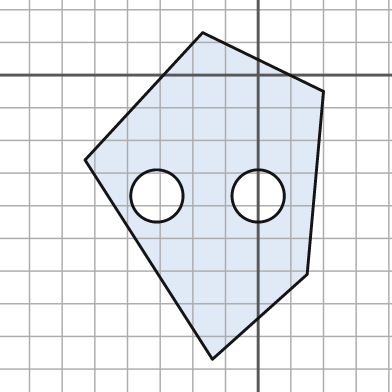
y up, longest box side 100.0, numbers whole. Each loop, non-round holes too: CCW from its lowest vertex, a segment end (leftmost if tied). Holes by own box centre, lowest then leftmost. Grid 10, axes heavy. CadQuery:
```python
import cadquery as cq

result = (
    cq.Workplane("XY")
    .moveTo(-14.0, -87.0)
    .lineTo(15.0, -61.0)
    .lineTo(20.0, -5.0)
    .lineTo(-17.0, 13.0)
    .lineTo(-53.0, -26.0)
    .close()
    .moveTo(-31.0, -37.0)
    .circle(8.0)
    .moveTo(0.0, -37.0)
    .circle(8.0)
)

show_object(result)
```